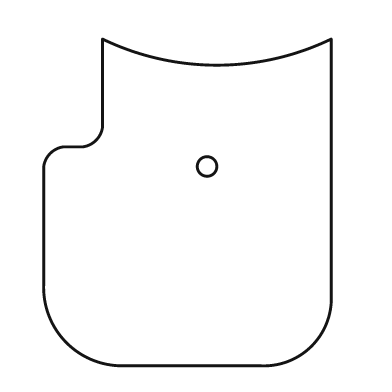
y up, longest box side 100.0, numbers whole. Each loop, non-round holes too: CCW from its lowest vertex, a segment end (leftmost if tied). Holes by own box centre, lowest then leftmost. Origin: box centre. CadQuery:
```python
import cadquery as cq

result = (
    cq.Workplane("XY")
    .moveTo(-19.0, -50.0)
    .lineTo(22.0, -50.0)
    .threePointArc((38.0, -44.0), (44.0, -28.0))
    .lineTo(44.0, 50.0)
    .threePointArc((9.0, 42.0), (-26.0, 50.0))
    .lineTo(-26.0, 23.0)
    .threePointArc((-28.0, 19.0), (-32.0, 17.0))
    .lineTo(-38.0, 17.0)
    .threePointArc((-42.0, 15.0), (-44.0, 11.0))
    .lineTo(-44.0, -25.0)
    .threePointArc((-37.0, -43.0), (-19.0, -50.0))
    .close()
    .moveTo(6.0, 11.0)
    .circle(3.0)
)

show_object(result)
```